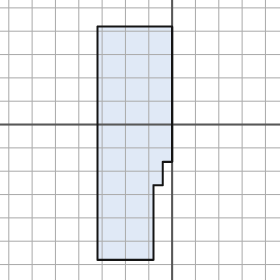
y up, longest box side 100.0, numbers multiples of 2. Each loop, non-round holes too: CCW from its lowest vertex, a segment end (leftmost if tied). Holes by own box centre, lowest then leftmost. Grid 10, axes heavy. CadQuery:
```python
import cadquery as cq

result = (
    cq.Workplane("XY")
    .moveTo(-32.0, -58.0)
    .lineTo(-8.0, -58.0)
    .lineTo(-8.0, -26.0)
    .lineTo(-4.0, -26.0)
    .lineTo(-4.0, -16.0)
    .lineTo(0.0, -16.0)
    .lineTo(0.0, 42.0)
    .lineTo(-32.0, 42.0)
    .close()
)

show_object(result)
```